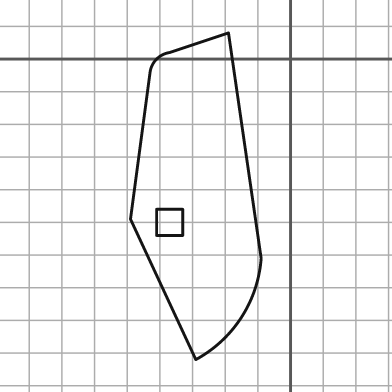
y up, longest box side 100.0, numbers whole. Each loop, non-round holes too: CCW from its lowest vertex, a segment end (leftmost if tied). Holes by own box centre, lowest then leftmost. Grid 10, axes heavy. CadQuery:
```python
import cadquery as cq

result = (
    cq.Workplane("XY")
    .moveTo(-29.0, -92.0)
    .threePointArc((-15.0, -79.0), (-9.0, -61.0))
    .lineTo(-19.0, 8.0)
    .lineTo(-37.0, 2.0)
    .threePointArc((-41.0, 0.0), (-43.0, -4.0))
    .lineTo(-49.0, -49.0)
    .close()
    .moveTo(-41.0, -54.0)
    .lineTo(-33.0, -54.0)
    .lineTo(-33.0, -46.0)
    .lineTo(-41.0, -46.0)
    .close()
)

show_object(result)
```